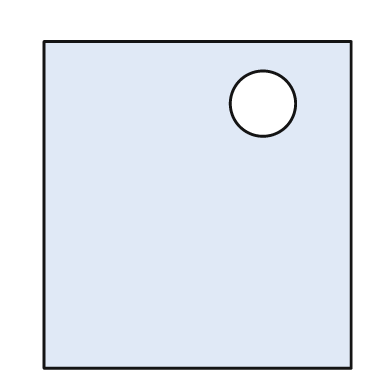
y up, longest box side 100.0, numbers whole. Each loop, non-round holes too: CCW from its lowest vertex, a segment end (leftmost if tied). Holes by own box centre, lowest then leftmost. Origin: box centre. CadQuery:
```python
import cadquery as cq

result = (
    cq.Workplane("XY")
    .moveTo(-47.0, -50.0)
    .lineTo(47.0, -50.0)
    .lineTo(47.0, 50.0)
    .lineTo(-47.0, 50.0)
    .close()
    .moveTo(20.0, 31.0)
    .circle(10.0)
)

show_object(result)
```